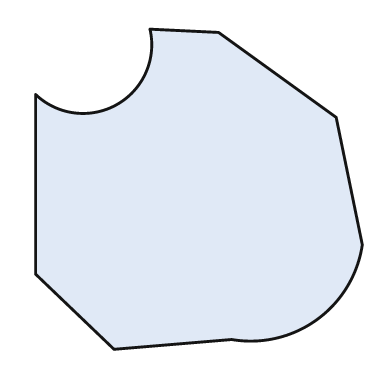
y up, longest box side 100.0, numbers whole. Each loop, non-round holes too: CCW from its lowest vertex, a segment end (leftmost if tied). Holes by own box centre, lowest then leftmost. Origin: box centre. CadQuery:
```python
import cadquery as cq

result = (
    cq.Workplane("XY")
    .moveTo(-26.0, -49.0)
    .lineTo(10.0, -46.0)
    .threePointArc((36.0, -40.0), (50.0, -17.0))
    .lineTo(42.0, 22.0)
    .lineTo(6.0, 48.0)
    .lineTo(-15.0, 49.0)
    .threePointArc((-25.0, 26.0), (-50.0, 29.0))
    .lineTo(-50.0, -26.0)
    .close()
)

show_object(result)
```